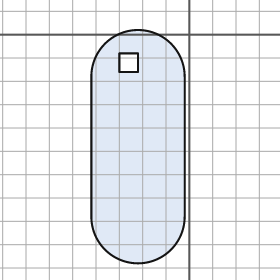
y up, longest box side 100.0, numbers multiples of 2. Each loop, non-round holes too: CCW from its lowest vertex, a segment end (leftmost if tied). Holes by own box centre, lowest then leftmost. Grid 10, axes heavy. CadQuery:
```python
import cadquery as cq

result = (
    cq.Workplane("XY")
    .moveTo(-42.0, -78.0)
    .threePointArc((-22.0, -98.0), (-2.0, -78.0))
    .lineTo(-2.0, -18.0)
    .threePointArc((-22.0, 2.0), (-42.0, -18.0))
    .close()
    .moveTo(-30.0, -16.0)
    .lineTo(-22.0, -16.0)
    .lineTo(-22.0, -8.0)
    .lineTo(-30.0, -8.0)
    .close()
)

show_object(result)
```